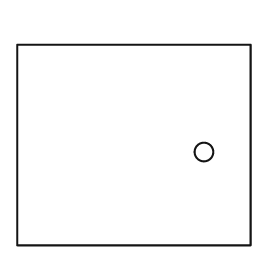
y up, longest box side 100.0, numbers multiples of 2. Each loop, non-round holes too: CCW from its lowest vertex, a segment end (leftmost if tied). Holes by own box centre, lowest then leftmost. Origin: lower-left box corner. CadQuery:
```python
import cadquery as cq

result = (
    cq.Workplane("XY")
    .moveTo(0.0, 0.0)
    .lineTo(100.0, 0.0)
    .lineTo(100.0, 86.0)
    .lineTo(0.0, 86.0)
    .close()
    .moveTo(80.0, 40.0)
    .circle(4.0)
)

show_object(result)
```